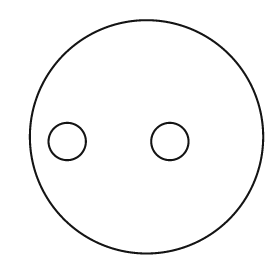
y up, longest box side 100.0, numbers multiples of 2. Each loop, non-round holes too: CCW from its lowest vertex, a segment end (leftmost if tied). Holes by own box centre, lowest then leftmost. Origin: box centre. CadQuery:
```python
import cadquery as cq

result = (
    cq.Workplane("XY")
    .moveTo(0.0, 0.0)
    .circle(50.0)
    .moveTo(-34.0, -2.0)
    .circle(8.0)
    .moveTo(10.0, -2.0)
    .circle(8.0)
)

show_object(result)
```